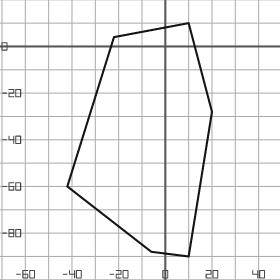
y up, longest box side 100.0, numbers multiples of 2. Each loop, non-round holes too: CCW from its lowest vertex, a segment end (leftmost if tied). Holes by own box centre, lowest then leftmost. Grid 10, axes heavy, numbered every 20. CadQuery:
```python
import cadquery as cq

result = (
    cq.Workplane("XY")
    .moveTo(10.0, -90.0)
    .lineTo(20.0, -28.0)
    .lineTo(10.0, 10.0)
    .lineTo(-22.0, 4.0)
    .lineTo(-42.0, -60.0)
    .lineTo(-6.0, -88.0)
    .close()
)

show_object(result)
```